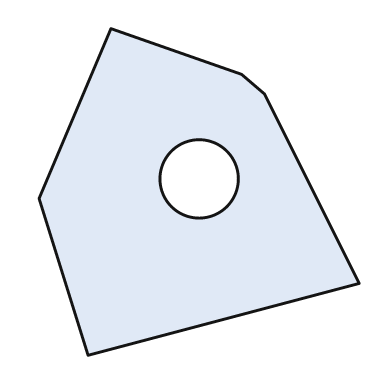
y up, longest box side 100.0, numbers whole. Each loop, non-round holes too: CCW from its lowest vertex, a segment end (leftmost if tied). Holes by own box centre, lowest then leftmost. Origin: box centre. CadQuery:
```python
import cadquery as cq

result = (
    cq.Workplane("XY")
    .moveTo(-34.0, -50.0)
    .lineTo(49.0, -28.0)
    .lineTo(20.0, 30.0)
    .lineTo(13.0, 36.0)
    .lineTo(-27.0, 50.0)
    .lineTo(-49.0, -2.0)
    .close()
    .moveTo(0.0, 4.0)
    .circle(12.0)
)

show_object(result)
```